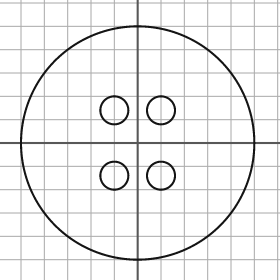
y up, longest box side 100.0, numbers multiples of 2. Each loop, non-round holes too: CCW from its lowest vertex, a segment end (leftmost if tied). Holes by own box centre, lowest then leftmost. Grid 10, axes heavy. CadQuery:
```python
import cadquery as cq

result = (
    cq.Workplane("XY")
    .moveTo(0.0, 0.0)
    .circle(50.0)
    .moveTo(-10.0, -14.0)
    .circle(6.0)
    .moveTo(10.0, -14.0)
    .circle(6.0)
    .moveTo(-10.0, 14.0)
    .circle(6.0)
    .moveTo(10.0, 14.0)
    .circle(6.0)
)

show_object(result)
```